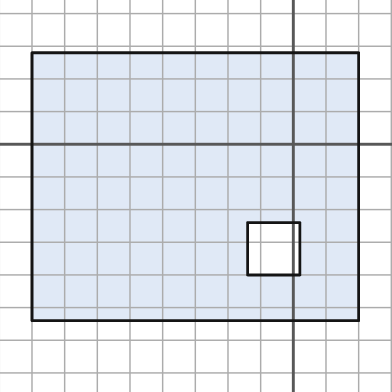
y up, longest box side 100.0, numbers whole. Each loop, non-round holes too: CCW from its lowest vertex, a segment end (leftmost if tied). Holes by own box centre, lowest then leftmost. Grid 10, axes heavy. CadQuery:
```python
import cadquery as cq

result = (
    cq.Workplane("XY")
    .moveTo(-80.0, -54.0)
    .lineTo(20.0, -54.0)
    .lineTo(20.0, 28.0)
    .lineTo(-80.0, 28.0)
    .close()
    .moveTo(-14.0, -40.0)
    .lineTo(2.0, -40.0)
    .lineTo(2.0, -24.0)
    .lineTo(-14.0, -24.0)
    .close()
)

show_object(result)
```